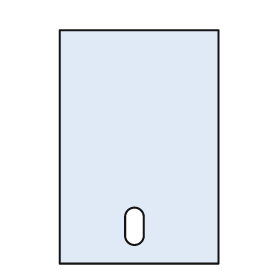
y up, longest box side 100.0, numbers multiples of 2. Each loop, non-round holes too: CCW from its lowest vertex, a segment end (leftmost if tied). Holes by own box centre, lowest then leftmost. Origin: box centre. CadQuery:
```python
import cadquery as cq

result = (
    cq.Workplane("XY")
    .moveTo(-34.0, -50.0)
    .lineTo(34.0, -50.0)
    .lineTo(34.0, 50.0)
    .lineTo(-34.0, 50.0)
    .close()
    .moveTo(-6.0, -38.0)
    .threePointArc((-2.0, -42.0), (2.0, -38.0))
    .lineTo(2.0, -30.0)
    .threePointArc((-2.0, -26.0), (-6.0, -30.0))
    .close()
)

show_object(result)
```